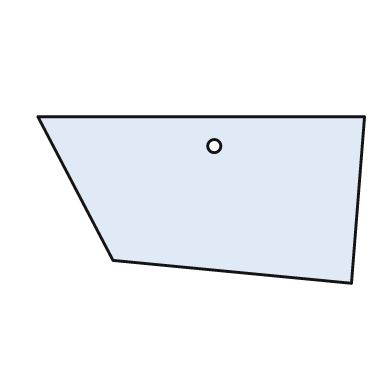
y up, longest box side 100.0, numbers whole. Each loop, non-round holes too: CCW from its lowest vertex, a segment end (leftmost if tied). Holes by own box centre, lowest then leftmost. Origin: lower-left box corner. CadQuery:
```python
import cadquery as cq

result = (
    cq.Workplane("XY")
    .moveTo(96.0, 0.0)
    .lineTo(100.0, 51.0)
    .lineTo(0.0, 51.0)
    .lineTo(23.0, 7.0)
    .close()
    .moveTo(54.0, 42.0)
    .circle(2.0)
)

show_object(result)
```